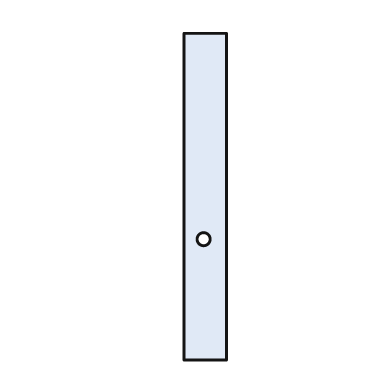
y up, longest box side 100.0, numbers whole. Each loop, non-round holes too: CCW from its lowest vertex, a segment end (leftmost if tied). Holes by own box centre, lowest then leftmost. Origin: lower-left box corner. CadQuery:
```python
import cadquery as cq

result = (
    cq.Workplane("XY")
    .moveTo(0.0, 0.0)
    .lineTo(13.0, 0.0)
    .lineTo(13.0, 100.0)
    .lineTo(0.0, 100.0)
    .close()
    .moveTo(6.0, 37.0)
    .circle(2.0)
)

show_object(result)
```